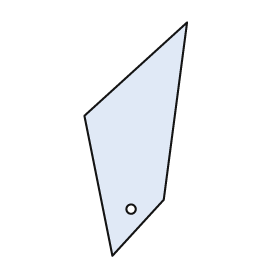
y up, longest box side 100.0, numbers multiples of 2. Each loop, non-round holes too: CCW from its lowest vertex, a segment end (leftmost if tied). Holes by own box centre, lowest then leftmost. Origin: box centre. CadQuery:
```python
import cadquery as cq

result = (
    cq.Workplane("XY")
    .moveTo(-10.0, -50.0)
    .lineTo(12.0, -26.0)
    .lineTo(22.0, 50.0)
    .lineTo(-22.0, 10.0)
    .close()
    .moveTo(-2.0, -30.0)
    .circle(2.0)
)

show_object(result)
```